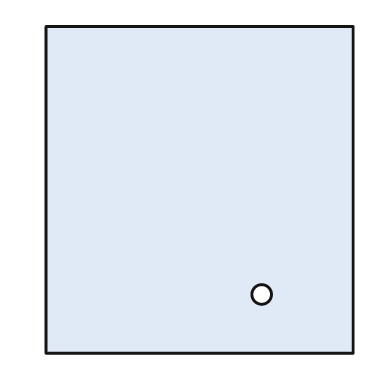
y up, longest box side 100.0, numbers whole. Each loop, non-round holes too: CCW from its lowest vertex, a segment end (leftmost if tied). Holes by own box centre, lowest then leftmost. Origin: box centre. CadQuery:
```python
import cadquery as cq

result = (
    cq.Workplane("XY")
    .moveTo(-47.0, -50.0)
    .lineTo(47.0, -50.0)
    .lineTo(47.0, 50.0)
    .lineTo(-47.0, 50.0)
    .close()
    .moveTo(19.0, -32.0)
    .circle(3.0)
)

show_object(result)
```